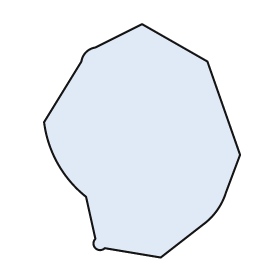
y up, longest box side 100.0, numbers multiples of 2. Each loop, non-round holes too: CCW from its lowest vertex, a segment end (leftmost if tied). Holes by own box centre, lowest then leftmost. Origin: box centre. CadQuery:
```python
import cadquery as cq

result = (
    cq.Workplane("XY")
    .moveTo(8.0, -50.0)
    .lineTo(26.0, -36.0)
    .threePointArc((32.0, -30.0), (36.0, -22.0))
    .lineTo(42.0, -6.0)
    .lineTo(28.0, 34.0)
    .lineTo(0.0, 50.0)
    .lineTo(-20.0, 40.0)
    .threePointArc((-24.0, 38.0), (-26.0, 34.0))
    .lineTo(-42.0, 8.0)
    .threePointArc((-36.0, -10.0), (-24.0, -24.0))
    .lineTo(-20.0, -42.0)
    .threePointArc((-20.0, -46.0), (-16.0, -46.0))
    .close()
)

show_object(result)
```